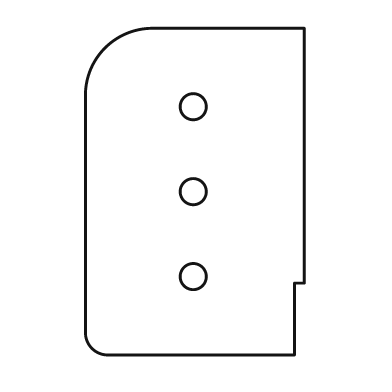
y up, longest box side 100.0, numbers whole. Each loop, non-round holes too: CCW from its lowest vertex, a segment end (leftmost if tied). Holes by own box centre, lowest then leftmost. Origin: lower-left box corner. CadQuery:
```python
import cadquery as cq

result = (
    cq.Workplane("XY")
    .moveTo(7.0, 0.0)
    .lineTo(64.0, 0.0)
    .lineTo(64.0, 22.0)
    .lineTo(67.0, 22.0)
    .lineTo(67.0, 100.0)
    .lineTo(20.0, 100.0)
    .threePointArc((6.0, 94.0), (0.0, 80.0))
    .lineTo(0.0, 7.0)
    .threePointArc((2.0, 2.0), (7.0, 0.0))
    .close()
    .moveTo(33.0, 24.0)
    .circle(4.0)
    .moveTo(33.0, 50.0)
    .circle(4.0)
    .moveTo(33.0, 76.0)
    .circle(4.0)
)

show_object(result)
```